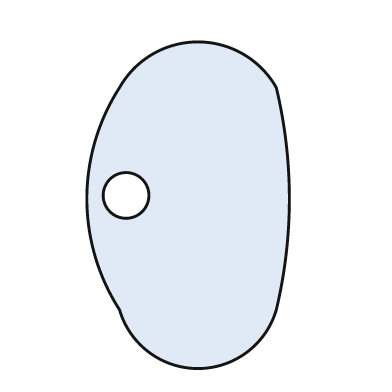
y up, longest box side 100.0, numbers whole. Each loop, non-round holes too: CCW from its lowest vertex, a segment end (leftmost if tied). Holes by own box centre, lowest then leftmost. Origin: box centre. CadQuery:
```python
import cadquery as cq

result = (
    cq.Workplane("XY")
    .moveTo(-21.0, -32.0)
    .threePointArc((3.0, -50.0), (27.0, -32.0))
    .threePointArc((31.0, 2.0), (27.0, 36.0))
    .threePointArc((3.0, 50.0), (-21.0, 36.0))
    .threePointArc((-31.0, 2.0), (-21.0, -32.0))
    .close()
    .moveTo(-19.0, 3.0)
    .circle(7.0)
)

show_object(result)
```